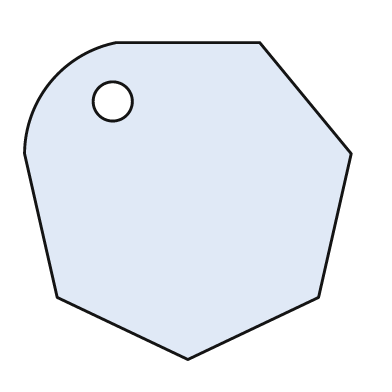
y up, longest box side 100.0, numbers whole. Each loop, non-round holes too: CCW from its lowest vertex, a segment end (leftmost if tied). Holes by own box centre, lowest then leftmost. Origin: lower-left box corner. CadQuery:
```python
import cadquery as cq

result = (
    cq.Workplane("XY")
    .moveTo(50.0, 0.0)
    .lineTo(90.0, 19.0)
    .lineTo(100.0, 63.0)
    .lineTo(72.0, 97.0)
    .lineTo(28.0, 97.0)
    .threePointArc((8.0, 85.0), (0.0, 63.0))
    .lineTo(10.0, 19.0)
    .close()
    .moveTo(27.0, 79.0)
    .circle(6.0)
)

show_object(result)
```